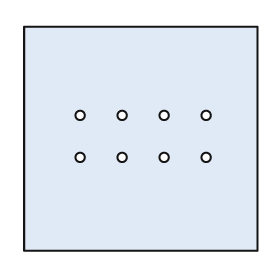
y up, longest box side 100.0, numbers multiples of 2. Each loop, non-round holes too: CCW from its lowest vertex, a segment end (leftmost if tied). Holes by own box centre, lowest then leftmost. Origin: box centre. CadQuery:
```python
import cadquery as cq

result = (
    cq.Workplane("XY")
    .moveTo(-50.0, -48.0)
    .lineTo(50.0, -48.0)
    .lineTo(50.0, 48.0)
    .lineTo(-50.0, 48.0)
    .close()
    .moveTo(-26.0, -8.0)
    .circle(2.0)
    .moveTo(-8.0, -8.0)
    .circle(2.0)
    .moveTo(10.0, -8.0)
    .circle(2.0)
    .moveTo(28.0, -8.0)
    .circle(2.0)
    .moveTo(-26.0, 10.0)
    .circle(2.0)
    .moveTo(-8.0, 10.0)
    .circle(2.0)
    .moveTo(10.0, 10.0)
    .circle(2.0)
    .moveTo(28.0, 10.0)
    .circle(2.0)
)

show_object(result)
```